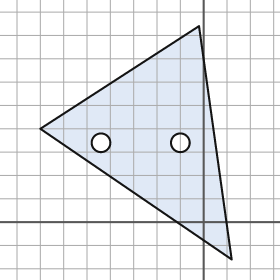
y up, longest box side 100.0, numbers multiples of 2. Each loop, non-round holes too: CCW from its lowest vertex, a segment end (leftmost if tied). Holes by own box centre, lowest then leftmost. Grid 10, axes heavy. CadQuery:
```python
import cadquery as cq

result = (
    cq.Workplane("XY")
    .moveTo(12.0, -16.0)
    .lineTo(-2.0, 84.0)
    .lineTo(-70.0, 40.0)
    .close()
    .moveTo(-44.0, 34.0)
    .circle(4.0)
    .moveTo(-10.0, 34.0)
    .circle(4.0)
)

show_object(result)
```